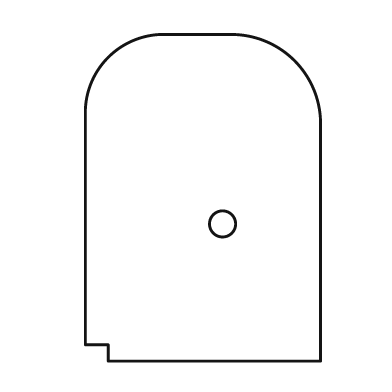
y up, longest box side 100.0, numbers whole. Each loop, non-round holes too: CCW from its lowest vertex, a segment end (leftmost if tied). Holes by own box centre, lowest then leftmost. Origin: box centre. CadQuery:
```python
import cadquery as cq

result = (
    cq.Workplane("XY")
    .moveTo(-29.0, -50.0)
    .lineTo(36.0, -50.0)
    .lineTo(36.0, 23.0)
    .threePointArc((28.0, 42.0), (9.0, 50.0))
    .lineTo(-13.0, 50.0)
    .threePointArc((-29.0, 43.0), (-36.0, 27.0))
    .lineTo(-36.0, -45.0)
    .lineTo(-29.0, -45.0)
    .close()
    .moveTo(6.0, -8.0)
    .circle(4.0)
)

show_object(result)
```